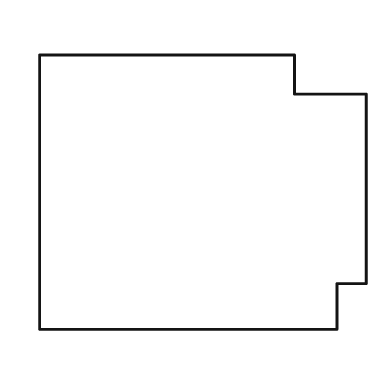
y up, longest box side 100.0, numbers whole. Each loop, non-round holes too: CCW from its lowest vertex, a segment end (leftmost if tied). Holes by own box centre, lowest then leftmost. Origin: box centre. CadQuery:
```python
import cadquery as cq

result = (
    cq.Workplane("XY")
    .moveTo(-50.0, -42.0)
    .lineTo(41.0, -42.0)
    .lineTo(41.0, -28.0)
    .lineTo(50.0, -28.0)
    .lineTo(50.0, 30.0)
    .lineTo(28.0, 30.0)
    .lineTo(28.0, 42.0)
    .lineTo(-50.0, 42.0)
    .close()
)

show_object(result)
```